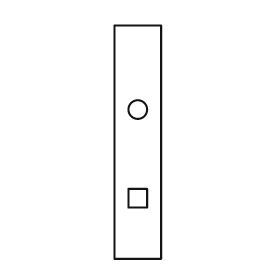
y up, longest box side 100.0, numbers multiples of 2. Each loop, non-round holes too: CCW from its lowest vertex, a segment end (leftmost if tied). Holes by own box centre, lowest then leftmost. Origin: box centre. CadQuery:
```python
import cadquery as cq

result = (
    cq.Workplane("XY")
    .moveTo(-10.0, -50.0)
    .lineTo(10.0, -50.0)
    .lineTo(10.0, 50.0)
    .lineTo(-10.0, 50.0)
    .close()
    .moveTo(-4.0, -28.0)
    .lineTo(4.0, -28.0)
    .lineTo(4.0, -20.0)
    .lineTo(-4.0, -20.0)
    .close()
    .moveTo(0.0, 14.0)
    .circle(4.0)
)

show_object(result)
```